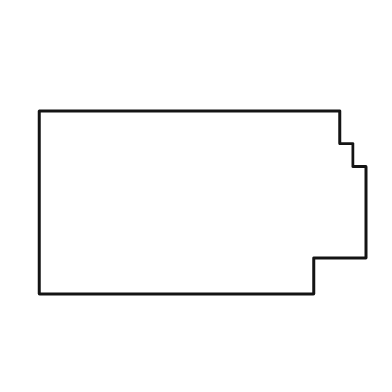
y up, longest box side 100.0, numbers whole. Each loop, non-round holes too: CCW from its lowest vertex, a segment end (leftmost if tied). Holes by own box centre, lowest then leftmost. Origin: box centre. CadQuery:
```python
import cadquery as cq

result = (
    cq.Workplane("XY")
    .moveTo(-50.0, -28.0)
    .lineTo(34.0, -28.0)
    .lineTo(34.0, -17.0)
    .lineTo(50.0, -17.0)
    .lineTo(50.0, 11.0)
    .lineTo(46.0, 11.0)
    .lineTo(46.0, 18.0)
    .lineTo(42.0, 18.0)
    .lineTo(42.0, 28.0)
    .lineTo(-50.0, 28.0)
    .close()
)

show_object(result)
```